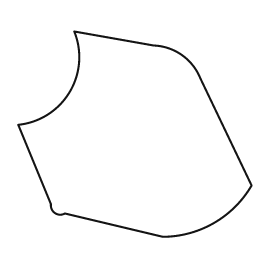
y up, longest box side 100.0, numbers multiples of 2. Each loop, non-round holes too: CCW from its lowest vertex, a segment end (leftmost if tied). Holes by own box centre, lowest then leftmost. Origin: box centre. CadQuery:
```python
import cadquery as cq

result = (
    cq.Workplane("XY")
    .moveTo(12.0, -44.0)
    .threePointArc((34.0, -38.0), (50.0, -22.0))
    .lineTo(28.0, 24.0)
    .threePointArc((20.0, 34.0), (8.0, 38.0))
    .lineTo(-26.0, 44.0)
    .threePointArc((-28.0, 18.0), (-50.0, 4.0))
    .lineTo(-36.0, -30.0)
    .threePointArc((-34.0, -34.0), (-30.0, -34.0))
    .close()
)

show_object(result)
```